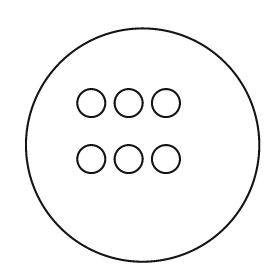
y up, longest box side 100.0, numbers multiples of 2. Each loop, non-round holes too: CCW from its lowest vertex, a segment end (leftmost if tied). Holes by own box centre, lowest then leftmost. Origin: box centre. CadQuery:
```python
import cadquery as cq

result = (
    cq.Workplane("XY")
    .moveTo(0.0, 0.0)
    .circle(50.0)
    .moveTo(-22.0, -6.0)
    .circle(6.0)
    .moveTo(-6.0, -6.0)
    .circle(6.0)
    .moveTo(10.0, -6.0)
    .circle(6.0)
    .moveTo(-22.0, 18.0)
    .circle(6.0)
    .moveTo(-6.0, 18.0)
    .circle(6.0)
    .moveTo(10.0, 18.0)
    .circle(6.0)
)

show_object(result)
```